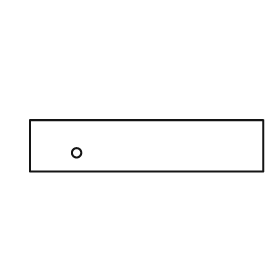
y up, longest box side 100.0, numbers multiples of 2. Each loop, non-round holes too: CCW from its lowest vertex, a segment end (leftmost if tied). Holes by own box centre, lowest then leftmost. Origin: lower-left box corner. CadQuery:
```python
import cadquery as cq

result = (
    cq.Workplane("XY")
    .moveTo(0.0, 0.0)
    .lineTo(100.0, 0.0)
    .lineTo(100.0, 22.0)
    .lineTo(0.0, 22.0)
    .close()
    .moveTo(20.0, 8.0)
    .circle(2.0)
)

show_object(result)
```